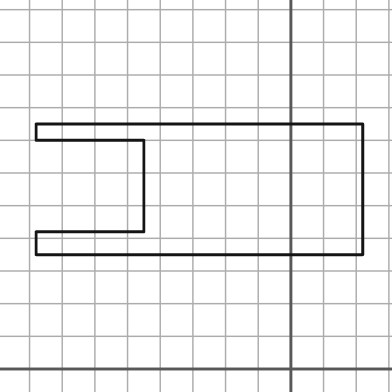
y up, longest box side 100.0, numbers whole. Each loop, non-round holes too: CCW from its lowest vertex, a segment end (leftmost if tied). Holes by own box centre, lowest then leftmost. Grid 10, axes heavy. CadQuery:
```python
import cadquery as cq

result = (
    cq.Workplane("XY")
    .moveTo(-78.0, 35.0)
    .lineTo(22.0, 35.0)
    .lineTo(22.0, 75.0)
    .lineTo(-78.0, 75.0)
    .lineTo(-78.0, 70.0)
    .lineTo(-45.0, 70.0)
    .lineTo(-45.0, 42.0)
    .lineTo(-78.0, 42.0)
    .close()
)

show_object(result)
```